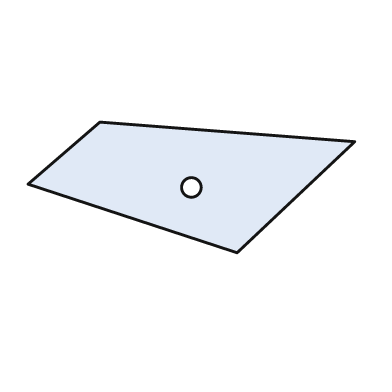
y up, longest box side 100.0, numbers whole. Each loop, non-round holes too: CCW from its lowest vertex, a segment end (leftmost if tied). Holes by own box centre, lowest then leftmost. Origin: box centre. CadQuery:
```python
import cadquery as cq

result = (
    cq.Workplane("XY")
    .moveTo(14.0, -20.0)
    .lineTo(50.0, 14.0)
    .lineTo(-28.0, 20.0)
    .lineTo(-50.0, 1.0)
    .close()
    .moveTo(0.0, 0.0)
    .circle(3.0)
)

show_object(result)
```